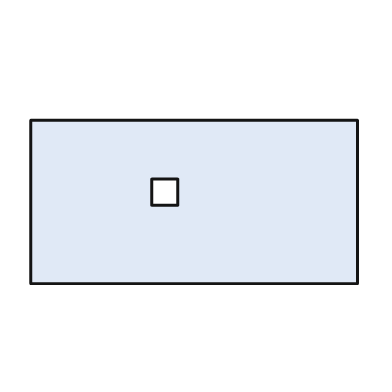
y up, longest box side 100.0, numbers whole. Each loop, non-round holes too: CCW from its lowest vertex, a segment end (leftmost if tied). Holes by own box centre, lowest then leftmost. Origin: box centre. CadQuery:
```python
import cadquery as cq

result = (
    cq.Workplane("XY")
    .moveTo(-50.0, -25.0)
    .lineTo(50.0, -25.0)
    .lineTo(50.0, 25.0)
    .lineTo(-50.0, 25.0)
    .close()
    .moveTo(-13.0, -1.0)
    .lineTo(-5.0, -1.0)
    .lineTo(-5.0, 7.0)
    .lineTo(-13.0, 7.0)
    .close()
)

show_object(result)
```